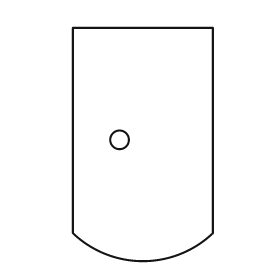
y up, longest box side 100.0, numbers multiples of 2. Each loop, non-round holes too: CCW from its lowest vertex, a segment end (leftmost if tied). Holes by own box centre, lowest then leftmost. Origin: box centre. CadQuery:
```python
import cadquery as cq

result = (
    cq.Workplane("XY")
    .moveTo(-30.0, -38.0)
    .threePointArc((0.0, -50.0), (30.0, -38.0))
    .lineTo(30.0, 50.0)
    .lineTo(-30.0, 50.0)
    .close()
    .moveTo(-10.0, 2.0)
    .circle(4.0)
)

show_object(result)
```